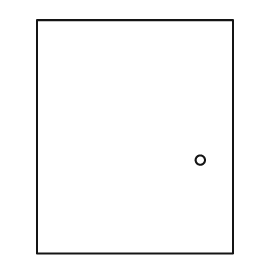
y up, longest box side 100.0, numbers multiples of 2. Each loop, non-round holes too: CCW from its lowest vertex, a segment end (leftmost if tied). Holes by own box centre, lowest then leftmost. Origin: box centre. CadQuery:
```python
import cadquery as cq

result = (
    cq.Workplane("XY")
    .moveTo(-42.0, -50.0)
    .lineTo(42.0, -50.0)
    .lineTo(42.0, 50.0)
    .lineTo(-42.0, 50.0)
    .close()
    .moveTo(28.0, -10.0)
    .circle(2.0)
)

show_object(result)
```